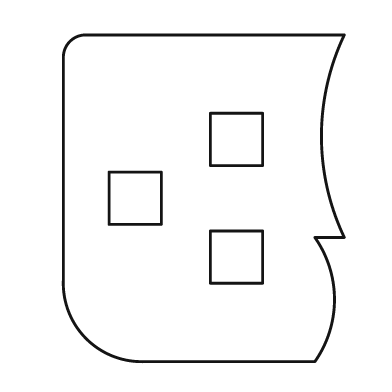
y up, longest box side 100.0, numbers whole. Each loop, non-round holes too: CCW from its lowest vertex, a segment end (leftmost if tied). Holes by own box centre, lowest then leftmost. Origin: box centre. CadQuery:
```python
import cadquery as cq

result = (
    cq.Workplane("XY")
    .moveTo(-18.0, -50.0)
    .lineTo(34.0, -50.0)
    .threePointArc((40.0, -31.0), (34.0, -12.0))
    .lineTo(43.0, -12.0)
    .threePointArc((36.0, 19.0), (43.0, 50.0))
    .lineTo(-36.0, 50.0)
    .threePointArc((-41.0, 48.0), (-43.0, 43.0))
    .lineTo(-43.0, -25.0)
    .threePointArc((-36.0, -43.0), (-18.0, -50.0))
    .close()
    .moveTo(2.0, -26.0)
    .lineTo(18.0, -26.0)
    .lineTo(18.0, -10.0)
    .lineTo(2.0, -10.0)
    .close()
    .moveTo(-29.0, -8.0)
    .lineTo(-13.0, -8.0)
    .lineTo(-13.0, 8.0)
    .lineTo(-29.0, 8.0)
    .close()
    .moveTo(2.0, 10.0)
    .lineTo(18.0, 10.0)
    .lineTo(18.0, 26.0)
    .lineTo(2.0, 26.0)
    .close()
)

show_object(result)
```